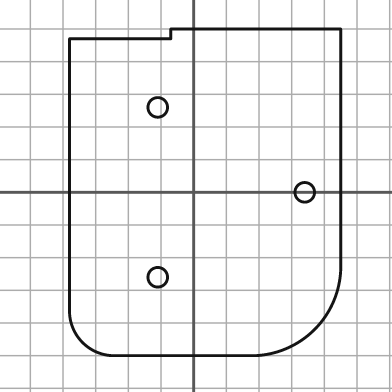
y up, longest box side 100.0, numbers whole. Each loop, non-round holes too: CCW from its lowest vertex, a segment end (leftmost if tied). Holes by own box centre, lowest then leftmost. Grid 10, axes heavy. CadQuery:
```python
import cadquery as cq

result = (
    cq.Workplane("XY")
    .moveTo(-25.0, -50.0)
    .lineTo(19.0, -50.0)
    .threePointArc((37.0, -42.0), (45.0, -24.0))
    .lineTo(45.0, 50.0)
    .lineTo(-7.0, 50.0)
    .lineTo(-7.0, 47.0)
    .lineTo(-38.0, 47.0)
    .lineTo(-38.0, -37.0)
    .threePointArc((-34.0, -46.0), (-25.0, -50.0))
    .close()
    .moveTo(-11.0, -26.0)
    .circle(3.0)
    .moveTo(34.0, 0.0)
    .circle(3.0)
    .moveTo(-11.0, 26.0)
    .circle(3.0)
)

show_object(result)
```